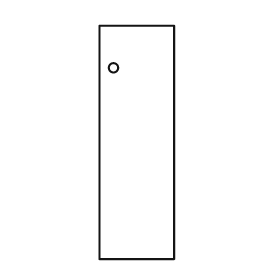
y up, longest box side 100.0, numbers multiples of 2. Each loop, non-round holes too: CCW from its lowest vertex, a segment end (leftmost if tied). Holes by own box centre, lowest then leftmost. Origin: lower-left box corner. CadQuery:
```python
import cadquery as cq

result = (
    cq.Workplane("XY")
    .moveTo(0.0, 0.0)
    .lineTo(32.0, 0.0)
    .lineTo(32.0, 100.0)
    .lineTo(0.0, 100.0)
    .close()
    .moveTo(6.0, 82.0)
    .circle(2.0)
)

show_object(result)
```